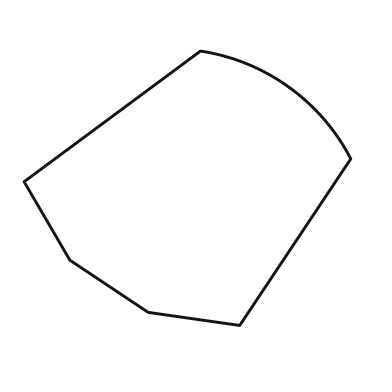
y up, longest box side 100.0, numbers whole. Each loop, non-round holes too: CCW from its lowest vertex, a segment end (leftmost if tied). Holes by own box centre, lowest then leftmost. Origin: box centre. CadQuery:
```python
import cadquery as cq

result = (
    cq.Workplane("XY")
    .moveTo(16.0, -42.0)
    .lineTo(50.0, 9.0)
    .threePointArc((31.0, 31.0), (4.0, 42.0))
    .lineTo(-50.0, 2.0)
    .lineTo(-36.0, -22.0)
    .lineTo(-12.0, -38.0)
    .close()
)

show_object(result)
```